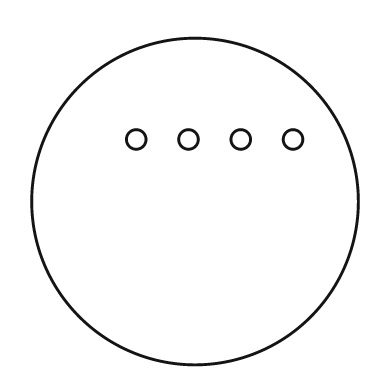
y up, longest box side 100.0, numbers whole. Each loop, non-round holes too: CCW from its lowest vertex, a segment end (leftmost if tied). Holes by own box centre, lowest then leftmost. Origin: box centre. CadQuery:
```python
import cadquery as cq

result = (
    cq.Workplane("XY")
    .moveTo(0.0, 0.0)
    .circle(50.0)
    .moveTo(-18.0, 19.0)
    .circle(3.0)
    .moveTo(-2.0, 19.0)
    .circle(3.0)
    .moveTo(14.0, 19.0)
    .circle(3.0)
    .moveTo(30.0, 19.0)
    .circle(3.0)
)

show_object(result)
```